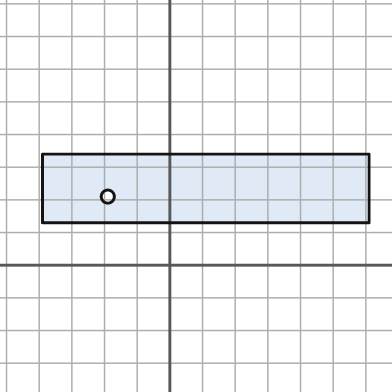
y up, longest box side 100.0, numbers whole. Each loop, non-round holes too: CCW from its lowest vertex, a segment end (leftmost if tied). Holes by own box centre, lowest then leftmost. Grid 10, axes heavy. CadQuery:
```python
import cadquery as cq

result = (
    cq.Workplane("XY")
    .moveTo(-39.0, 13.0)
    .lineTo(61.0, 13.0)
    .lineTo(61.0, 34.0)
    .lineTo(-39.0, 34.0)
    .close()
    .moveTo(-19.0, 21.0)
    .circle(2.0)
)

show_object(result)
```